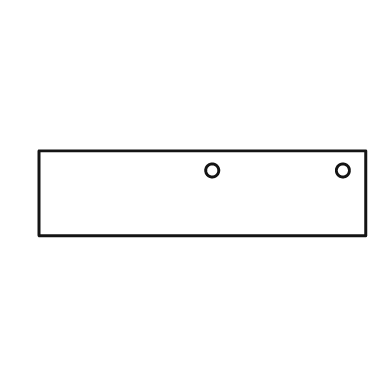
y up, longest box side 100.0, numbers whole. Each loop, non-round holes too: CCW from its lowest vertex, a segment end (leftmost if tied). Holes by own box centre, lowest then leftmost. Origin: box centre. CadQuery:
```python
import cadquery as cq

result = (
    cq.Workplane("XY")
    .moveTo(-50.0, -13.0)
    .lineTo(50.0, -13.0)
    .lineTo(50.0, 13.0)
    .lineTo(-50.0, 13.0)
    .close()
    .moveTo(3.0, 7.0)
    .circle(2.0)
    .moveTo(43.0, 7.0)
    .circle(2.0)
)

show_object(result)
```